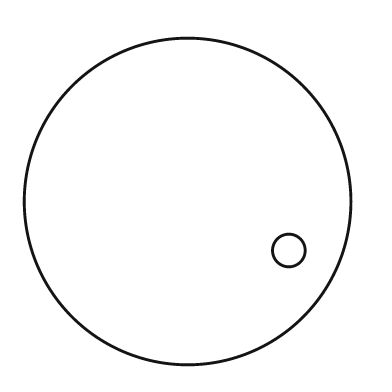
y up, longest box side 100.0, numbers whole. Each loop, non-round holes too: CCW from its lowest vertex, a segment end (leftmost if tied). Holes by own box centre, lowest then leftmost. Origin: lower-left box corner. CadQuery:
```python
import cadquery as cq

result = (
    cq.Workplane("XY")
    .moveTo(50.0, 50.0)
    .circle(50.0)
    .moveTo(81.0, 35.0)
    .circle(5.0)
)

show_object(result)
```